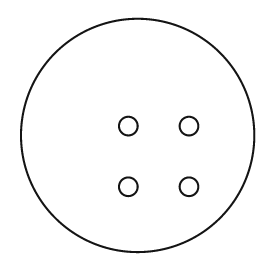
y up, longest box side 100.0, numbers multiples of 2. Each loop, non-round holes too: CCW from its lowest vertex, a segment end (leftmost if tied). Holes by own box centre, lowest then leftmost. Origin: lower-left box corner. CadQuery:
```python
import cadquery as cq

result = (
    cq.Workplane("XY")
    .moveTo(50.0, 50.0)
    .circle(50.0)
    .moveTo(46.0, 28.0)
    .circle(4.0)
    .moveTo(72.0, 28.0)
    .circle(4.0)
    .moveTo(46.0, 54.0)
    .circle(4.0)
    .moveTo(72.0, 54.0)
    .circle(4.0)
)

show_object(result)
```